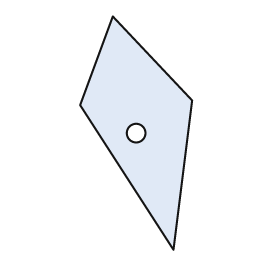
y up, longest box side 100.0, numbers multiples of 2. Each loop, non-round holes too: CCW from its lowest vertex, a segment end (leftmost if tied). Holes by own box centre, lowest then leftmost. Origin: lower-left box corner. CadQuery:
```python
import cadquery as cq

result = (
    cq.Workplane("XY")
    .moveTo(40.0, 0.0)
    .lineTo(48.0, 64.0)
    .lineTo(14.0, 100.0)
    .lineTo(0.0, 62.0)
    .close()
    .moveTo(24.0, 50.0)
    .circle(4.0)
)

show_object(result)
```